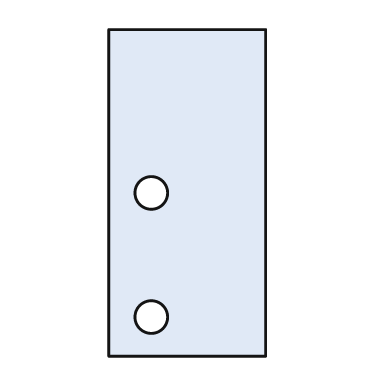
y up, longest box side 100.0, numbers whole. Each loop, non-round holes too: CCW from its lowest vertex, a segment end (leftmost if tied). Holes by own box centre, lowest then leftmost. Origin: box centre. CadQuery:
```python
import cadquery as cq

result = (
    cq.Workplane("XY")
    .moveTo(-24.0, -50.0)
    .lineTo(24.0, -50.0)
    .lineTo(24.0, 50.0)
    .lineTo(-24.0, 50.0)
    .close()
    .moveTo(-11.0, -38.0)
    .circle(5.0)
    .moveTo(-11.0, 0.0)
    .circle(5.0)
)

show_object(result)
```